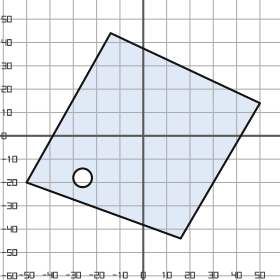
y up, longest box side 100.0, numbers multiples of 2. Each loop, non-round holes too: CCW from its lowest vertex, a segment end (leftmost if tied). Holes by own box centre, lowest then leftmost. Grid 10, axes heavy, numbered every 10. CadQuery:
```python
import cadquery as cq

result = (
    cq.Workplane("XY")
    .moveTo(16.0, -44.0)
    .lineTo(50.0, 14.0)
    .lineTo(-14.0, 44.0)
    .lineTo(-50.0, -20.0)
    .close()
    .moveTo(-26.0, -18.0)
    .circle(4.0)
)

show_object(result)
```